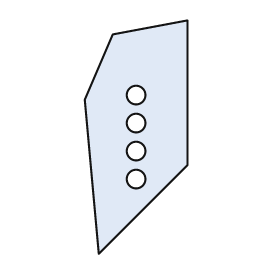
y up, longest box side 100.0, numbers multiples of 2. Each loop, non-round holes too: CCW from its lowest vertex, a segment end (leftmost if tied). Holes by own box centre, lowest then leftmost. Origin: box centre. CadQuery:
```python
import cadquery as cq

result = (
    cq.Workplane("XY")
    .moveTo(-16.0, -50.0)
    .lineTo(22.0, -12.0)
    .lineTo(22.0, 50.0)
    .lineTo(-10.0, 44.0)
    .lineTo(-22.0, 16.0)
    .close()
    .moveTo(0.0, -18.0)
    .circle(4.0)
    .moveTo(0.0, -6.0)
    .circle(4.0)
    .moveTo(0.0, 6.0)
    .circle(4.0)
    .moveTo(0.0, 18.0)
    .circle(4.0)
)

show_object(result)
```